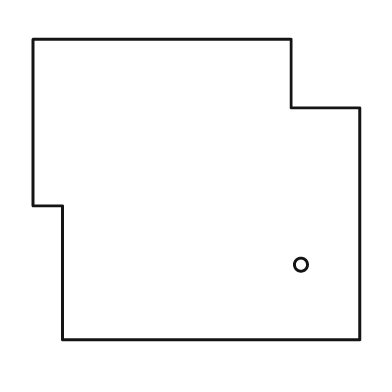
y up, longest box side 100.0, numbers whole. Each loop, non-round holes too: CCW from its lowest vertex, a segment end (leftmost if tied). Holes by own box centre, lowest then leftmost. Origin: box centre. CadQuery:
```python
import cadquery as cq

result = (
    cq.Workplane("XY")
    .moveTo(-41.0, -46.0)
    .lineTo(50.0, -46.0)
    .lineTo(50.0, 25.0)
    .lineTo(29.0, 25.0)
    .lineTo(29.0, 46.0)
    .lineTo(-50.0, 46.0)
    .lineTo(-50.0, -5.0)
    .lineTo(-41.0, -5.0)
    .close()
    .moveTo(32.0, -23.0)
    .circle(2.0)
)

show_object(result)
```